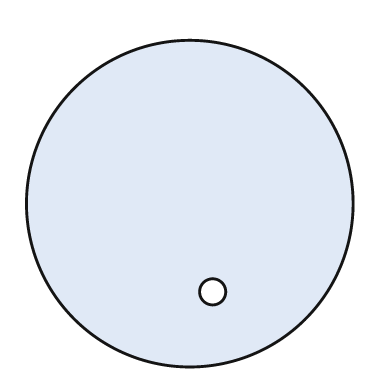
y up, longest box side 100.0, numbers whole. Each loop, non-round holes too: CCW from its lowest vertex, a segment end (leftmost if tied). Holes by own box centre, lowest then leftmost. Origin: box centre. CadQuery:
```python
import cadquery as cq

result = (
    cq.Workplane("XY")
    .moveTo(0.0, 0.0)
    .circle(50.0)
    .moveTo(7.0, -27.0)
    .circle(4.0)
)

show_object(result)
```